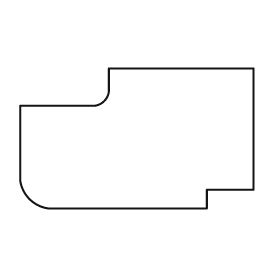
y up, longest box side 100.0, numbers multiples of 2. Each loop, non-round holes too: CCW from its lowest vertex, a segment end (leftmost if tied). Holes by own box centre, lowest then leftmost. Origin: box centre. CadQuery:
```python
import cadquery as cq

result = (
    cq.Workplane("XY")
    .moveTo(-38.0, -30.0)
    .lineTo(30.0, -30.0)
    .lineTo(30.0, -22.0)
    .lineTo(50.0, -22.0)
    .lineTo(50.0, 30.0)
    .lineTo(-12.0, 30.0)
    .lineTo(-12.0, 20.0)
    .threePointArc((-14.0, 16.0), (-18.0, 14.0))
    .lineTo(-50.0, 14.0)
    .lineTo(-50.0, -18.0)
    .threePointArc((-46.0, -26.0), (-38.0, -30.0))
    .close()
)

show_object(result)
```